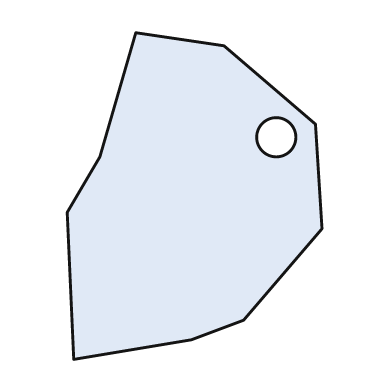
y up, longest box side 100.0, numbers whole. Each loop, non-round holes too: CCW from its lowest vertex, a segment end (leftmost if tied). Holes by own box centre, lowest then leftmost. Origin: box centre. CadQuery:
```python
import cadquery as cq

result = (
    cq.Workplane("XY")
    .moveTo(-37.0, -50.0)
    .lineTo(-1.0, -44.0)
    .lineTo(15.0, -38.0)
    .lineTo(39.0, -10.0)
    .lineTo(37.0, 22.0)
    .lineTo(9.0, 46.0)
    .lineTo(-18.0, 50.0)
    .lineTo(-29.0, 12.0)
    .lineTo(-39.0, -5.0)
    .close()
    .moveTo(25.0, 18.0)
    .circle(6.0)
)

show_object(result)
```